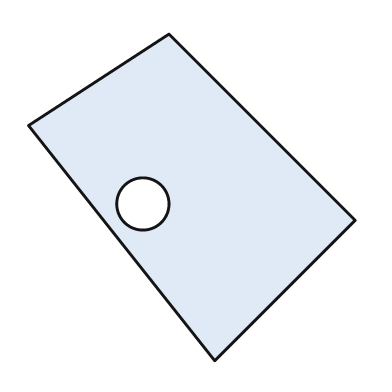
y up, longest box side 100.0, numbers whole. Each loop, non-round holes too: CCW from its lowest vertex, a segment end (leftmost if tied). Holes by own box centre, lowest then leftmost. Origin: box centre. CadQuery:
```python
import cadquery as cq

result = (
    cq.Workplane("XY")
    .moveTo(7.0, -50.0)
    .lineTo(50.0, -7.0)
    .lineTo(-7.0, 50.0)
    .lineTo(-50.0, 22.0)
    .close()
    .moveTo(-15.0, -2.0)
    .circle(8.0)
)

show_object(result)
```